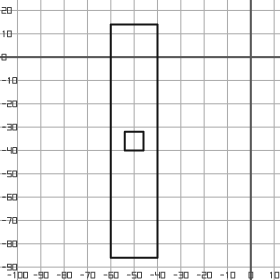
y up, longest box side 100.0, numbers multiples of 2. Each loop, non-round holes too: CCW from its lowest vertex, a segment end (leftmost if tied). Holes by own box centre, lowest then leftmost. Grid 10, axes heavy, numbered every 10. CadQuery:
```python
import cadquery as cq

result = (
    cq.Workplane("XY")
    .moveTo(-60.0, -86.0)
    .lineTo(-40.0, -86.0)
    .lineTo(-40.0, 14.0)
    .lineTo(-60.0, 14.0)
    .close()
    .moveTo(-54.0, -40.0)
    .lineTo(-46.0, -40.0)
    .lineTo(-46.0, -32.0)
    .lineTo(-54.0, -32.0)
    .close()
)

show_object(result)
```